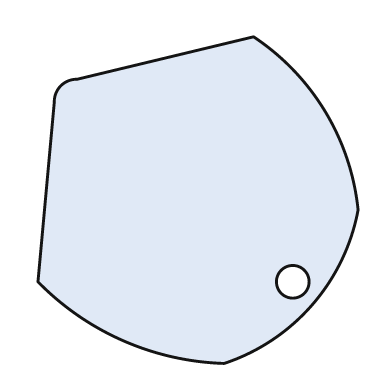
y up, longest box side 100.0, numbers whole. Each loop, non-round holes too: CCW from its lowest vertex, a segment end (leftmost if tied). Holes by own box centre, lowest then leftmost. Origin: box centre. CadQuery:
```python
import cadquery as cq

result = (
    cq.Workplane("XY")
    .moveTo(8.0, -50.0)
    .threePointArc((35.0, -32.0), (49.0, -3.0))
    .threePointArc((39.0, 27.0), (17.0, 50.0))
    .lineTo(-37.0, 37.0)
    .threePointArc((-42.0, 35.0), (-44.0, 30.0))
    .lineTo(-49.0, -25.0)
    .threePointArc((-23.0, -43.0), (8.0, -50.0))
    .close()
    .moveTo(29.0, -25.0)
    .circle(5.0)
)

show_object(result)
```